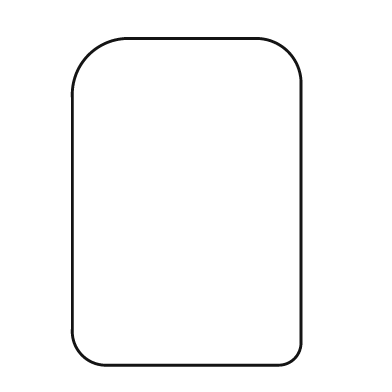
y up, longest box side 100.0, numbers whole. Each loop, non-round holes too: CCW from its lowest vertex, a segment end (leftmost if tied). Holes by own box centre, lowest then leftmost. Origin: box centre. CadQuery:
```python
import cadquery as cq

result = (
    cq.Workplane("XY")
    .moveTo(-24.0, -50.0)
    .lineTo(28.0, -50.0)
    .threePointArc((33.0, -48.0), (35.0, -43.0))
    .lineTo(35.0, 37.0)
    .threePointArc((31.0, 46.0), (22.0, 50.0))
    .lineTo(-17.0, 50.0)
    .threePointArc((-30.0, 45.0), (-35.0, 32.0))
    .lineTo(-35.0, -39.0)
    .threePointArc((-32.0, -47.0), (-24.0, -50.0))
    .close()
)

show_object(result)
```